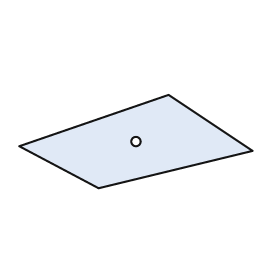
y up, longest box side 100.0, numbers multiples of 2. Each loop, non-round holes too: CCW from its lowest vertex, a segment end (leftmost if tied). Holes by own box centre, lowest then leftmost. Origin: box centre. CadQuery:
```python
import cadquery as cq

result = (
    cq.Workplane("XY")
    .moveTo(-16.0, -20.0)
    .lineTo(50.0, -4.0)
    .lineTo(14.0, 20.0)
    .lineTo(-50.0, -2.0)
    .close()
    .moveTo(0.0, 0.0)
    .circle(2.0)
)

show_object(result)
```